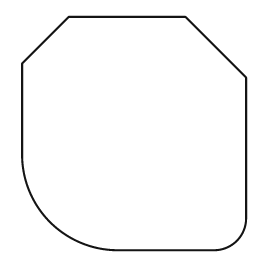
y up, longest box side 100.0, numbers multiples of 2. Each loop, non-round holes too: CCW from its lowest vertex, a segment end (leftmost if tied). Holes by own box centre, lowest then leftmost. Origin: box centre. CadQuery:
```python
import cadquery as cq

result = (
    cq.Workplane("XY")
    .moveTo(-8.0, -50.0)
    .lineTo(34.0, -50.0)
    .threePointArc((44.0, -46.0), (48.0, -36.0))
    .lineTo(48.0, 24.0)
    .lineTo(22.0, 50.0)
    .lineTo(-28.0, 50.0)
    .lineTo(-48.0, 30.0)
    .lineTo(-48.0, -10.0)
    .threePointArc((-36.0, -38.0), (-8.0, -50.0))
    .close()
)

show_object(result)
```